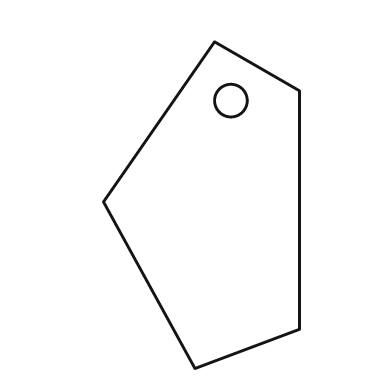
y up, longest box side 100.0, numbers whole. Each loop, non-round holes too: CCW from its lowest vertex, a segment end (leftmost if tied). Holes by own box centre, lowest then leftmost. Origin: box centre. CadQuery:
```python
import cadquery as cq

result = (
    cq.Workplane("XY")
    .moveTo(-2.0, -50.0)
    .lineTo(30.0, -38.0)
    .lineTo(30.0, 35.0)
    .lineTo(4.0, 50.0)
    .lineTo(-30.0, 1.0)
    .close()
    .moveTo(9.0, 32.0)
    .circle(5.0)
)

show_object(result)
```